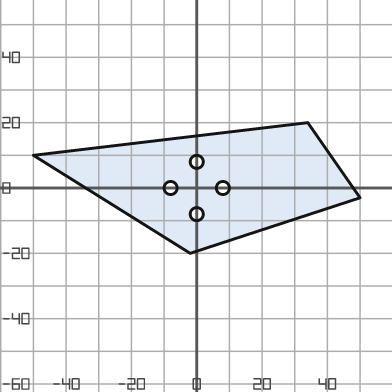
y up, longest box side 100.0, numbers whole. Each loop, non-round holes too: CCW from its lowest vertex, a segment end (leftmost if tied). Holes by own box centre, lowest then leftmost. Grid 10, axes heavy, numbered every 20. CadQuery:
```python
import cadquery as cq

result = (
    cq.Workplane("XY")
    .moveTo(-2.0, -20.0)
    .lineTo(50.0, -3.0)
    .lineTo(34.0, 20.0)
    .lineTo(-50.0, 10.0)
    .close()
    .moveTo(0.0, -8.0)
    .circle(2.0)
    .moveTo(-8.0, 0.0)
    .circle(2.0)
    .moveTo(8.0, 0.0)
    .circle(2.0)
    .moveTo(0.0, 8.0)
    .circle(2.0)
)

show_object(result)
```